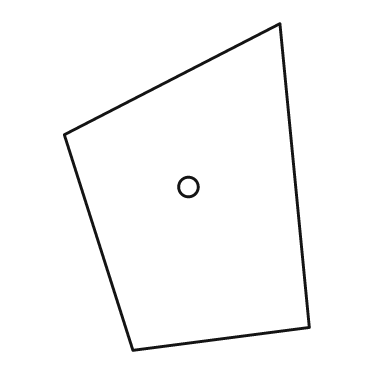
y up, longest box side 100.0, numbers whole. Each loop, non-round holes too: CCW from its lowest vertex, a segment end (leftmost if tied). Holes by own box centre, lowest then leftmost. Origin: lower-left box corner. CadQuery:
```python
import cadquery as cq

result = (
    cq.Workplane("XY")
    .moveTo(21.0, 0.0)
    .lineTo(75.0, 7.0)
    .lineTo(66.0, 100.0)
    .lineTo(0.0, 66.0)
    .close()
    .moveTo(38.0, 50.0)
    .circle(3.0)
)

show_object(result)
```